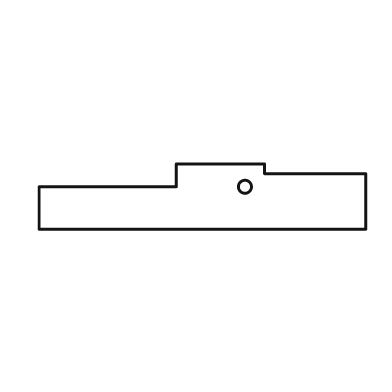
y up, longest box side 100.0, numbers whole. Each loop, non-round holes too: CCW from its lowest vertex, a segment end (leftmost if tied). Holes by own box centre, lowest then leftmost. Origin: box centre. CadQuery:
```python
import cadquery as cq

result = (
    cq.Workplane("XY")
    .moveTo(-50.0, -10.0)
    .lineTo(50.0, -10.0)
    .lineTo(50.0, 7.0)
    .lineTo(19.0, 7.0)
    .lineTo(19.0, 10.0)
    .lineTo(-8.0, 10.0)
    .lineTo(-8.0, 3.0)
    .lineTo(-50.0, 3.0)
    .close()
    .moveTo(13.0, 3.0)
    .circle(2.0)
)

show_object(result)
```